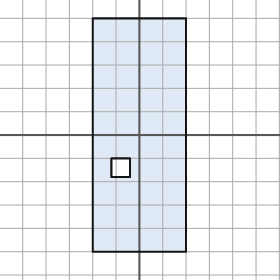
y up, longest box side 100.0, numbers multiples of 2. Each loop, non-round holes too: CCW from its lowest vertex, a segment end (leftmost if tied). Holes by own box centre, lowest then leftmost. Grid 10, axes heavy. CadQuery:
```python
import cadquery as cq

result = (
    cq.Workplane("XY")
    .moveTo(-20.0, -50.0)
    .lineTo(20.0, -50.0)
    .lineTo(20.0, 50.0)
    .lineTo(-20.0, 50.0)
    .close()
    .moveTo(-12.0, -18.0)
    .lineTo(-4.0, -18.0)
    .lineTo(-4.0, -10.0)
    .lineTo(-12.0, -10.0)
    .close()
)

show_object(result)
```